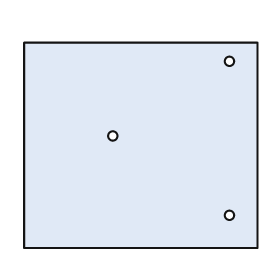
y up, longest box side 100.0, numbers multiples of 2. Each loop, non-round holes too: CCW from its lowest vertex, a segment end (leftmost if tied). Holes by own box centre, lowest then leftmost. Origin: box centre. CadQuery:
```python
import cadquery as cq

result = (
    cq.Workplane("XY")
    .moveTo(-50.0, -44.0)
    .lineTo(50.0, -44.0)
    .lineTo(50.0, 44.0)
    .lineTo(-50.0, 44.0)
    .close()
    .moveTo(38.0, -30.0)
    .circle(2.0)
    .moveTo(-12.0, 4.0)
    .circle(2.0)
    .moveTo(38.0, 36.0)
    .circle(2.0)
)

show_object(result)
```